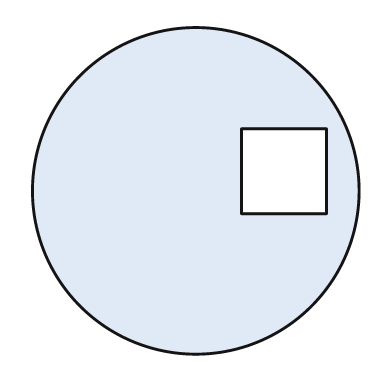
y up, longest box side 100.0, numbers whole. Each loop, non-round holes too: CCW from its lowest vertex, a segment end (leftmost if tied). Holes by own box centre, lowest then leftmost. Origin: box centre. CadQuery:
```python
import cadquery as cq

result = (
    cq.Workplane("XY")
    .moveTo(0.0, 0.0)
    .circle(50.0)
    .moveTo(14.0, -7.0)
    .lineTo(40.0, -7.0)
    .lineTo(40.0, 19.0)
    .lineTo(14.0, 19.0)
    .close()
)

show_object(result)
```